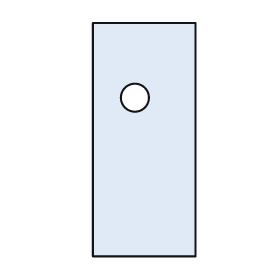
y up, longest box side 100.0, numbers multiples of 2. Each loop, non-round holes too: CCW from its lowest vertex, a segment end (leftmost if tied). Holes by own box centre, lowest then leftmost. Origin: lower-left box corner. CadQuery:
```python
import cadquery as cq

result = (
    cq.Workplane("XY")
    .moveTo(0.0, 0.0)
    .lineTo(44.0, 0.0)
    .lineTo(44.0, 100.0)
    .lineTo(0.0, 100.0)
    .close()
    .moveTo(18.0, 68.0)
    .circle(6.0)
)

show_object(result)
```